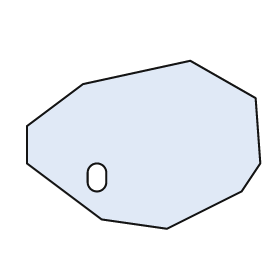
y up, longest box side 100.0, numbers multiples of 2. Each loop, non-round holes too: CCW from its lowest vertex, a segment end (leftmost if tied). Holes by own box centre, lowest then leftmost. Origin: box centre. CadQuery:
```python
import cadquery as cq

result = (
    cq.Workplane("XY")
    .moveTo(10.0, -36.0)
    .lineTo(42.0, -20.0)
    .lineTo(50.0, -8.0)
    .lineTo(48.0, 20.0)
    .lineTo(20.0, 36.0)
    .lineTo(-26.0, 26.0)
    .lineTo(-50.0, 8.0)
    .lineTo(-50.0, -8.0)
    .lineTo(-18.0, -32.0)
    .close()
    .moveTo(-24.0, -16.0)
    .threePointArc((-20.0, -20.0), (-16.0, -16.0))
    .lineTo(-16.0, -12.0)
    .threePointArc((-20.0, -8.0), (-24.0, -12.0))
    .close()
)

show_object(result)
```